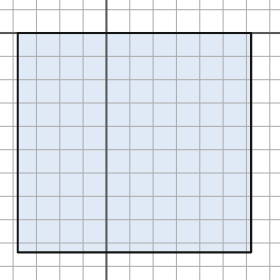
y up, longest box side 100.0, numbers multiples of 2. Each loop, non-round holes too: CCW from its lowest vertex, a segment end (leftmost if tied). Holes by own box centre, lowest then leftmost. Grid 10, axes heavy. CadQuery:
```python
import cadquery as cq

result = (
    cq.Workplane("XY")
    .moveTo(-38.0, -94.0)
    .lineTo(62.0, -94.0)
    .lineTo(62.0, 0.0)
    .lineTo(-38.0, 0.0)
    .close()
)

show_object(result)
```